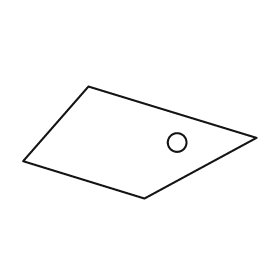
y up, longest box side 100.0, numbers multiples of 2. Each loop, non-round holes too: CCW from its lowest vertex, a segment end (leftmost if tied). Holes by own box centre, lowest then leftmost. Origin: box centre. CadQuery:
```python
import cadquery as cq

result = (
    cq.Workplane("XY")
    .moveTo(2.0, -24.0)
    .lineTo(50.0, 2.0)
    .lineTo(-22.0, 24.0)
    .lineTo(-50.0, -8.0)
    .close()
    .moveTo(16.0, 0.0)
    .circle(4.0)
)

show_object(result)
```